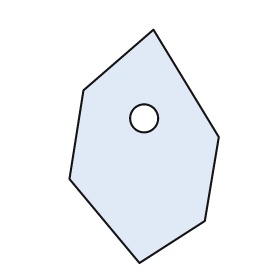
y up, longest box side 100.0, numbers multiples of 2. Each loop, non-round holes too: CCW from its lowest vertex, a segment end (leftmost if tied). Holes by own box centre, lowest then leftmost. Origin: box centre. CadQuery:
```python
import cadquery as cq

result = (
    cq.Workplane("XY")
    .moveTo(-2.0, -50.0)
    .lineTo(26.0, -32.0)
    .lineTo(32.0, 4.0)
    .lineTo(4.0, 50.0)
    .lineTo(-26.0, 24.0)
    .lineTo(-32.0, -14.0)
    .close()
    .moveTo(0.0, 12.0)
    .circle(6.0)
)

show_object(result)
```